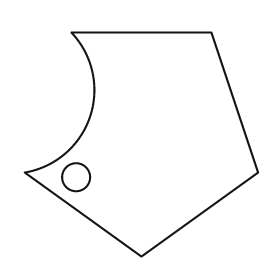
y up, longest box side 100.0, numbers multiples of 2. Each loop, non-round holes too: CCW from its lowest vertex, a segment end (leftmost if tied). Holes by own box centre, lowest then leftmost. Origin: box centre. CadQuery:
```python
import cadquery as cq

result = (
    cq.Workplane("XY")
    .moveTo(0.0, -48.0)
    .lineTo(50.0, -12.0)
    .lineTo(30.0, 48.0)
    .lineTo(-30.0, 48.0)
    .threePointArc((-22.0, 12.0), (-50.0, -12.0))
    .close()
    .moveTo(-28.0, -14.0)
    .circle(6.0)
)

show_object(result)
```